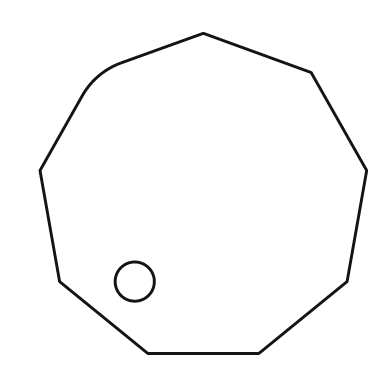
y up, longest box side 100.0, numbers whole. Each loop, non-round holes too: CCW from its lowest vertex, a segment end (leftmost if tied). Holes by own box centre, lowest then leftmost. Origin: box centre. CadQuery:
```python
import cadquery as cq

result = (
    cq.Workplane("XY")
    .moveTo(-17.0, -49.0)
    .lineTo(17.0, -49.0)
    .lineTo(44.0, -27.0)
    .lineTo(50.0, 7.0)
    .lineTo(33.0, 37.0)
    .lineTo(0.0, 49.0)
    .lineTo(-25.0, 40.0)
    .threePointArc((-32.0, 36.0), (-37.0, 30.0))
    .lineTo(-50.0, 7.0)
    .lineTo(-44.0, -27.0)
    .close()
    .moveTo(-21.0, -27.0)
    .circle(6.0)
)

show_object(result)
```